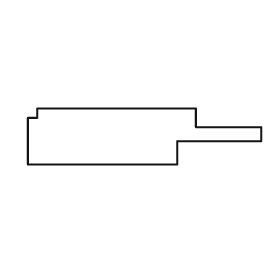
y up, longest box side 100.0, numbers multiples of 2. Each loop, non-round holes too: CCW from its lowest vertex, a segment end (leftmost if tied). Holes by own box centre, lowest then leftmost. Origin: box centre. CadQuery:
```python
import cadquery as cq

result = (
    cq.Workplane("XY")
    .moveTo(-50.0, -12.0)
    .lineTo(14.0, -12.0)
    .lineTo(14.0, -2.0)
    .lineTo(50.0, -2.0)
    .lineTo(50.0, 4.0)
    .lineTo(22.0, 4.0)
    .lineTo(22.0, 12.0)
    .lineTo(-46.0, 12.0)
    .lineTo(-46.0, 8.0)
    .lineTo(-50.0, 8.0)
    .close()
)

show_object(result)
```